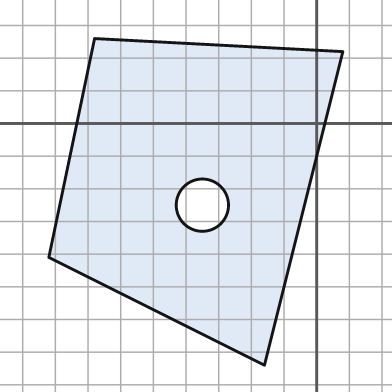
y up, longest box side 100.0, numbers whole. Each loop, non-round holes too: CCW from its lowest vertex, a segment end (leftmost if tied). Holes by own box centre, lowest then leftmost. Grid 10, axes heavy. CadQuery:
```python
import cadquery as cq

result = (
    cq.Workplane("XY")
    .moveTo(-16.0, -74.0)
    .lineTo(8.0, 22.0)
    .lineTo(-68.0, 26.0)
    .lineTo(-82.0, -41.0)
    .close()
    .moveTo(-35.0, -25.0)
    .circle(8.0)
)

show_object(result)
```